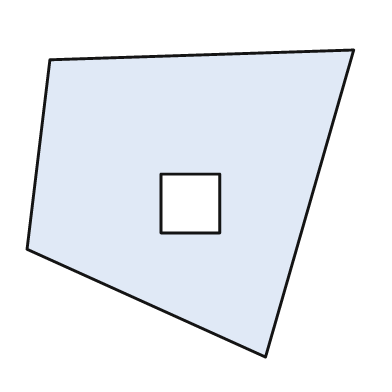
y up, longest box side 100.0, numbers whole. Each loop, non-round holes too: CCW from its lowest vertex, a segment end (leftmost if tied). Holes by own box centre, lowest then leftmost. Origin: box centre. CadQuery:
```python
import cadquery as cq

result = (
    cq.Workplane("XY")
    .moveTo(23.0, -47.0)
    .lineTo(50.0, 47.0)
    .lineTo(-43.0, 44.0)
    .lineTo(-50.0, -14.0)
    .close()
    .moveTo(-9.0, -9.0)
    .lineTo(9.0, -9.0)
    .lineTo(9.0, 9.0)
    .lineTo(-9.0, 9.0)
    .close()
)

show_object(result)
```